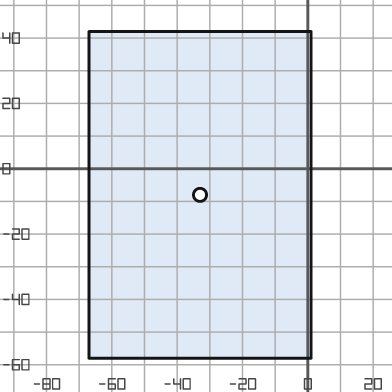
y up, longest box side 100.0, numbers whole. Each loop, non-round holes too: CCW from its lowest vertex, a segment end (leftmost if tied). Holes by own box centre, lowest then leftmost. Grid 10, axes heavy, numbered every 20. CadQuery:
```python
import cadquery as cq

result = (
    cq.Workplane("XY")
    .moveTo(-67.0, -58.0)
    .lineTo(1.0, -58.0)
    .lineTo(1.0, 42.0)
    .lineTo(-67.0, 42.0)
    .close()
    .moveTo(-33.0, -8.0)
    .circle(2.0)
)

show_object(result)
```